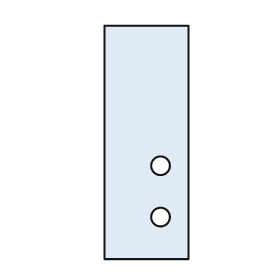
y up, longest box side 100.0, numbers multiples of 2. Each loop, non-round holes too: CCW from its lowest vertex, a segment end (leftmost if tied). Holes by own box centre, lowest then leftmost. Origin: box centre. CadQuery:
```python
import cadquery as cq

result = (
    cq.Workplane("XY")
    .moveTo(-18.0, -50.0)
    .lineTo(18.0, -50.0)
    .lineTo(18.0, 50.0)
    .lineTo(-18.0, 50.0)
    .close()
    .moveTo(6.0, -32.0)
    .circle(4.0)
    .moveTo(6.0, -10.0)
    .circle(4.0)
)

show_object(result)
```